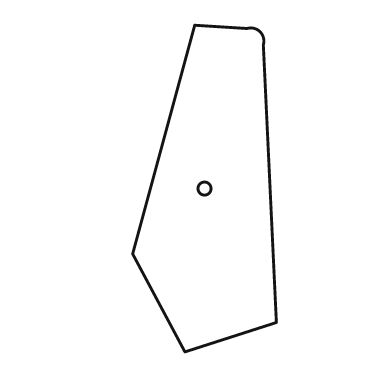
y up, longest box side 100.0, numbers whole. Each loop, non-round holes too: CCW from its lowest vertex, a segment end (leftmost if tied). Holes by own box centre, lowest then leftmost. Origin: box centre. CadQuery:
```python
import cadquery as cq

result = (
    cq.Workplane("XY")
    .moveTo(-6.0, -50.0)
    .lineTo(22.0, -41.0)
    .lineTo(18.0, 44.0)
    .threePointArc((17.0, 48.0), (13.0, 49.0))
    .lineTo(-3.0, 50.0)
    .lineTo(-22.0, -20.0)
    .close()
    .moveTo(0.0, 0.0)
    .circle(2.0)
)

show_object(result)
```